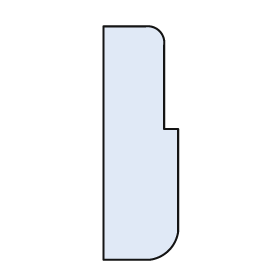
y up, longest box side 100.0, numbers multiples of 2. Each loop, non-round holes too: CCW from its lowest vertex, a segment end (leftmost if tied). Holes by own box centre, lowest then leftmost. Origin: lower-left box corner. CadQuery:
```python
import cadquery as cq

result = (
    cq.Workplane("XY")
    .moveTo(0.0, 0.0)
    .lineTo(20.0, 0.0)
    .threePointArc((28.0, 4.0), (32.0, 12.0))
    .lineTo(32.0, 56.0)
    .lineTo(26.0, 56.0)
    .lineTo(26.0, 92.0)
    .threePointArc((24.0, 98.0), (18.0, 100.0))
    .lineTo(0.0, 100.0)
    .close()
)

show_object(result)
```